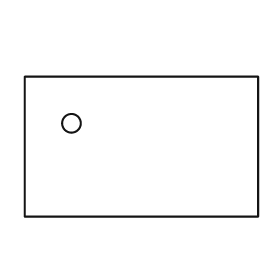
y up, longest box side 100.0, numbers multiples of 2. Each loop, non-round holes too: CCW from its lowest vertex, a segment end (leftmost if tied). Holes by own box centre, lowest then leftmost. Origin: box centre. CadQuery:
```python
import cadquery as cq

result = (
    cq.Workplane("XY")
    .moveTo(-50.0, -30.0)
    .lineTo(50.0, -30.0)
    .lineTo(50.0, 30.0)
    .lineTo(-50.0, 30.0)
    .close()
    .moveTo(-30.0, 10.0)
    .circle(4.0)
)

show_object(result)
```